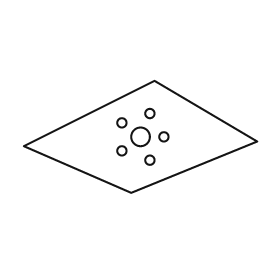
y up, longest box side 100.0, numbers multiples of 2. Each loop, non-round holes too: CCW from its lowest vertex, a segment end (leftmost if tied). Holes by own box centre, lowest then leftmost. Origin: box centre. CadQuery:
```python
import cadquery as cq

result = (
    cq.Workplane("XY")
    .moveTo(-4.0, -24.0)
    .lineTo(50.0, -2.0)
    .lineTo(6.0, 24.0)
    .lineTo(-50.0, -4.0)
    .close()
    .moveTo(4.0, -10.0)
    .circle(2.0)
    .moveTo(-8.0, -6.0)
    .circle(2.0)
    .moveTo(0.0, 0.0)
    .circle(4.0)
    .moveTo(10.0, 0.0)
    .circle(2.0)
    .moveTo(-8.0, 6.0)
    .circle(2.0)
    .moveTo(4.0, 10.0)
    .circle(2.0)
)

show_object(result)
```